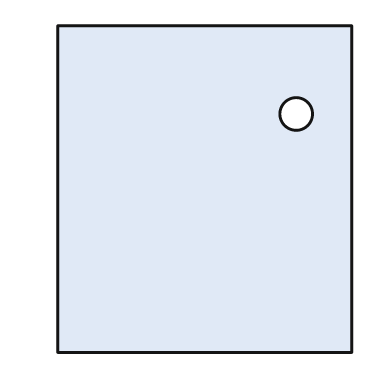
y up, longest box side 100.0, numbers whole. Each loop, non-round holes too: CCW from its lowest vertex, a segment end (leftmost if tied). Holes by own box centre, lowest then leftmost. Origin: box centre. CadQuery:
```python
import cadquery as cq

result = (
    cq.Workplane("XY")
    .moveTo(-45.0, -50.0)
    .lineTo(45.0, -50.0)
    .lineTo(45.0, 50.0)
    .lineTo(-45.0, 50.0)
    .close()
    .moveTo(28.0, 23.0)
    .circle(5.0)
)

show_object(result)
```